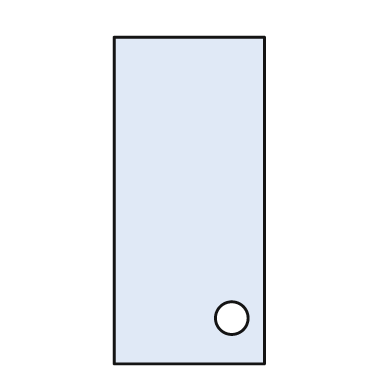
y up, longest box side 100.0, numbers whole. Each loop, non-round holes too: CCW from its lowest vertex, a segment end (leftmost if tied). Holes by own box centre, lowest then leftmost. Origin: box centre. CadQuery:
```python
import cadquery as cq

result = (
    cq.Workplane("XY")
    .moveTo(-23.0, -50.0)
    .lineTo(23.0, -50.0)
    .lineTo(23.0, 50.0)
    .lineTo(-23.0, 50.0)
    .close()
    .moveTo(13.0, -36.0)
    .circle(5.0)
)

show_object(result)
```